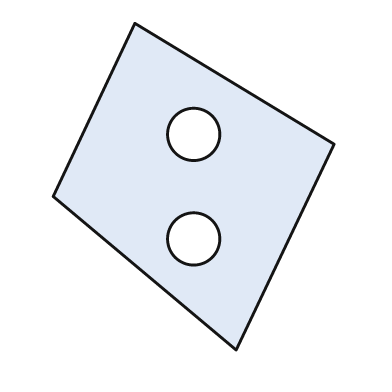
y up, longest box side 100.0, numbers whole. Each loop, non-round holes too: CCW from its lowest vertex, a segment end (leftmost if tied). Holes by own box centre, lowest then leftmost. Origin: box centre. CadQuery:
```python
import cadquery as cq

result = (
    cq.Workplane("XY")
    .moveTo(13.0, -50.0)
    .lineTo(43.0, 13.0)
    .lineTo(-18.0, 50.0)
    .lineTo(-43.0, -3.0)
    .close()
    .moveTo(0.0, -16.0)
    .circle(8.0)
    .moveTo(0.0, 16.0)
    .circle(8.0)
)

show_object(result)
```